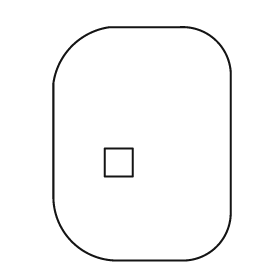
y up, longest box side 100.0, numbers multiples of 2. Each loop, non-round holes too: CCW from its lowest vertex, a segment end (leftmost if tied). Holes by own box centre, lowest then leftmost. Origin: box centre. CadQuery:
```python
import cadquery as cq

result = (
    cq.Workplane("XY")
    .moveTo(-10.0, -50.0)
    .lineTo(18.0, -50.0)
    .threePointArc((32.0, -44.0), (38.0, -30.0))
    .lineTo(38.0, 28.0)
    .threePointArc((32.0, 44.0), (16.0, 50.0))
    .lineTo(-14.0, 50.0)
    .threePointArc((-30.0, 42.0), (-38.0, 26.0))
    .lineTo(-38.0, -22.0)
    .threePointArc((-30.0, -42.0), (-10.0, -50.0))
    .close()
    .moveTo(-16.0, -14.0)
    .lineTo(-4.0, -14.0)
    .lineTo(-4.0, -2.0)
    .lineTo(-16.0, -2.0)
    .close()
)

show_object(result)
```